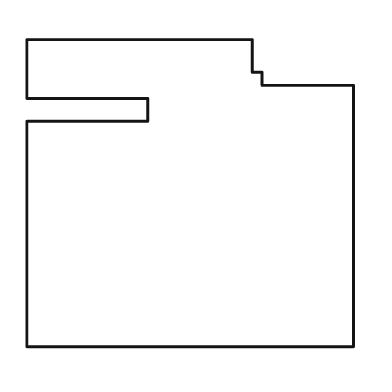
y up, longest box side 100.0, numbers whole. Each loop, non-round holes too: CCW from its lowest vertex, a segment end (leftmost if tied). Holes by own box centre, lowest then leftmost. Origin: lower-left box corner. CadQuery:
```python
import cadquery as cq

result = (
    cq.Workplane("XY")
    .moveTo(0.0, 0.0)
    .lineTo(100.0, 0.0)
    .lineTo(100.0, 80.0)
    .lineTo(72.0, 80.0)
    .lineTo(72.0, 84.0)
    .lineTo(69.0, 84.0)
    .lineTo(69.0, 94.0)
    .lineTo(0.0, 94.0)
    .lineTo(0.0, 76.0)
    .lineTo(37.0, 76.0)
    .lineTo(37.0, 69.0)
    .lineTo(0.0, 69.0)
    .close()
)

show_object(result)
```